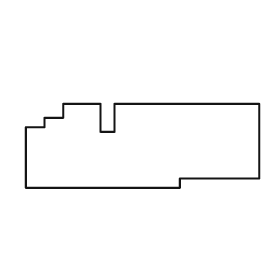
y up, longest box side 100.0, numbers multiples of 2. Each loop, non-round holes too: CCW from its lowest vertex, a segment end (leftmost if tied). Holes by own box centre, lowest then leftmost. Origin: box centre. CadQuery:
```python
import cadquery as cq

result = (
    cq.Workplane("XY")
    .moveTo(-50.0, -18.0)
    .lineTo(16.0, -18.0)
    .lineTo(16.0, -14.0)
    .lineTo(50.0, -14.0)
    .lineTo(50.0, 18.0)
    .lineTo(-12.0, 18.0)
    .lineTo(-12.0, 6.0)
    .lineTo(-18.0, 6.0)
    .lineTo(-18.0, 18.0)
    .lineTo(-34.0, 18.0)
    .lineTo(-34.0, 12.0)
    .lineTo(-42.0, 12.0)
    .lineTo(-42.0, 8.0)
    .lineTo(-50.0, 8.0)
    .close()
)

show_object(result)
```